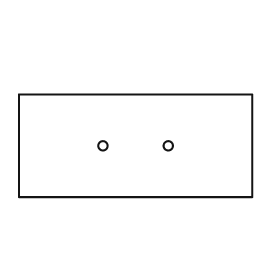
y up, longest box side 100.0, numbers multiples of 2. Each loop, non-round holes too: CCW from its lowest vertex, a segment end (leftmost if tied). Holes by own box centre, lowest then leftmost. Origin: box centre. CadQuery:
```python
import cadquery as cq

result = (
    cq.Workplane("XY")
    .moveTo(-50.0, -22.0)
    .lineTo(50.0, -22.0)
    .lineTo(50.0, 22.0)
    .lineTo(-50.0, 22.0)
    .close()
    .moveTo(-14.0, 0.0)
    .circle(2.0)
    .moveTo(14.0, 0.0)
    .circle(2.0)
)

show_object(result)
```